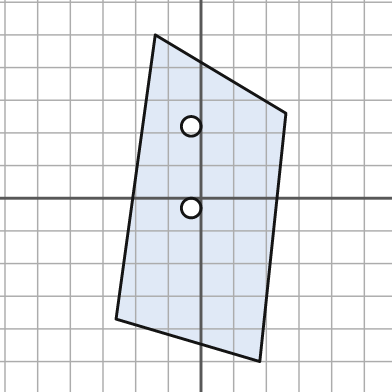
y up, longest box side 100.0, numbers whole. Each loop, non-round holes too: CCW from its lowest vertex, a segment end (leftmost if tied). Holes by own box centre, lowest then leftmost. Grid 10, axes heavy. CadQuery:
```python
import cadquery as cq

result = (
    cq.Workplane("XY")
    .moveTo(18.0, -50.0)
    .lineTo(26.0, 26.0)
    .lineTo(-14.0, 50.0)
    .lineTo(-26.0, -37.0)
    .close()
    .moveTo(-3.0, -3.0)
    .circle(3.0)
    .moveTo(-3.0, 22.0)
    .circle(3.0)
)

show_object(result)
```